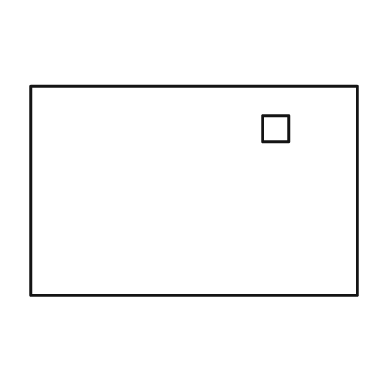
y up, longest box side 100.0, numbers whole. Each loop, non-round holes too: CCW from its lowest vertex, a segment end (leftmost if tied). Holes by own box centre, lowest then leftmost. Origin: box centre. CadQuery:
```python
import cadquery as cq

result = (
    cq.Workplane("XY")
    .moveTo(-50.0, -32.0)
    .lineTo(50.0, -32.0)
    .lineTo(50.0, 32.0)
    .lineTo(-50.0, 32.0)
    .close()
    .moveTo(21.0, 15.0)
    .lineTo(29.0, 15.0)
    .lineTo(29.0, 23.0)
    .lineTo(21.0, 23.0)
    .close()
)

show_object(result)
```